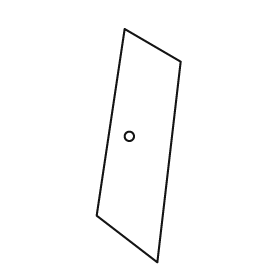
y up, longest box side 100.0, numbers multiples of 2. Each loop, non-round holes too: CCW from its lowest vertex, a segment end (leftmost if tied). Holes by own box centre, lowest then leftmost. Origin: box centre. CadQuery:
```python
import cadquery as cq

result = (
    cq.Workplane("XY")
    .moveTo(8.0, -50.0)
    .lineTo(18.0, 36.0)
    .lineTo(-6.0, 50.0)
    .lineTo(-18.0, -30.0)
    .close()
    .moveTo(-4.0, 4.0)
    .circle(2.0)
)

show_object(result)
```